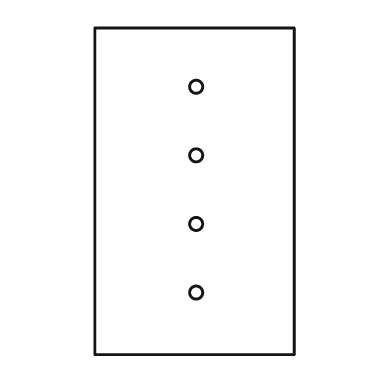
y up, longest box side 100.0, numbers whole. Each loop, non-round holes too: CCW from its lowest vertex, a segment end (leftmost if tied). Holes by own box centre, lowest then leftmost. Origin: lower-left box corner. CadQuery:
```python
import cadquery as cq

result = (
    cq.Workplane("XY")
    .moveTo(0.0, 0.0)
    .lineTo(61.0, 0.0)
    .lineTo(61.0, 100.0)
    .lineTo(0.0, 100.0)
    .close()
    .moveTo(31.0, 19.0)
    .circle(2.0)
    .moveTo(31.0, 40.0)
    .circle(2.0)
    .moveTo(31.0, 61.0)
    .circle(2.0)
    .moveTo(31.0, 82.0)
    .circle(2.0)
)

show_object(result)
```